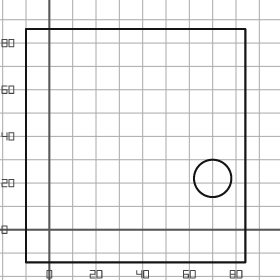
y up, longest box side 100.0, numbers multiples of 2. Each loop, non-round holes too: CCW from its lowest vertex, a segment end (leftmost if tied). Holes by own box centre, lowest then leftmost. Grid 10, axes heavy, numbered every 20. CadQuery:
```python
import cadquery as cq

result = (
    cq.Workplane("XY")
    .moveTo(-10.0, -14.0)
    .lineTo(84.0, -14.0)
    .lineTo(84.0, 86.0)
    .lineTo(-10.0, 86.0)
    .close()
    .moveTo(70.0, 22.0)
    .circle(8.0)
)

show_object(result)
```